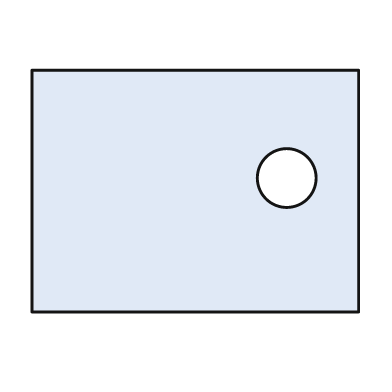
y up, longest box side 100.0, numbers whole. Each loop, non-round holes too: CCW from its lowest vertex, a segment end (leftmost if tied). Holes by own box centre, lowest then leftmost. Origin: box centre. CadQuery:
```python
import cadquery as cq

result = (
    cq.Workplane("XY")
    .moveTo(-50.0, -37.0)
    .lineTo(50.0, -37.0)
    .lineTo(50.0, 37.0)
    .lineTo(-50.0, 37.0)
    .close()
    .moveTo(28.0, 4.0)
    .circle(9.0)
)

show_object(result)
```